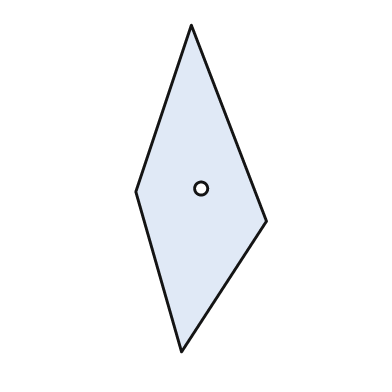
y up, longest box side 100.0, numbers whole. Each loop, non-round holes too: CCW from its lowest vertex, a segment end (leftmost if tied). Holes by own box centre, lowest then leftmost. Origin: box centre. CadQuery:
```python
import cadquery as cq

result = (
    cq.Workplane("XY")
    .moveTo(-6.0, -50.0)
    .lineTo(20.0, -10.0)
    .lineTo(-3.0, 50.0)
    .lineTo(-20.0, -1.0)
    .close()
    .moveTo(0.0, 0.0)
    .circle(2.0)
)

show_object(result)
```